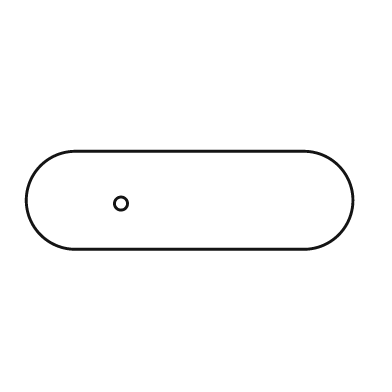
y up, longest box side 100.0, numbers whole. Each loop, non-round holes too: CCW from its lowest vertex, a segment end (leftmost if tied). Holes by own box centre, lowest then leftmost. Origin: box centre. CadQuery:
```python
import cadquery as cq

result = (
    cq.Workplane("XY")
    .moveTo(-35.0, -15.0)
    .lineTo(35.0, -15.0)
    .threePointArc((50.0, 0.0), (35.0, 15.0))
    .lineTo(-35.0, 15.0)
    .threePointArc((-50.0, 0.0), (-35.0, -15.0))
    .close()
    .moveTo(-21.0, -1.0)
    .circle(2.0)
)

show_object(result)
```